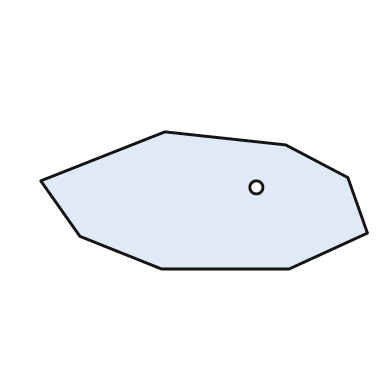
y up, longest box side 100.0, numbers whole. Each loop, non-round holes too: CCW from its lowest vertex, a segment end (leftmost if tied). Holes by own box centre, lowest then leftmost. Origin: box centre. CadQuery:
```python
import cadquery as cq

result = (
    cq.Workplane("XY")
    .moveTo(-13.0, -21.0)
    .lineTo(26.0, -21.0)
    .lineTo(50.0, -10.0)
    .lineTo(44.0, 7.0)
    .lineTo(25.0, 17.0)
    .lineTo(-12.0, 21.0)
    .lineTo(-50.0, 6.0)
    .lineTo(-38.0, -11.0)
    .close()
    .moveTo(16.0, 4.0)
    .circle(2.0)
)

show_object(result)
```